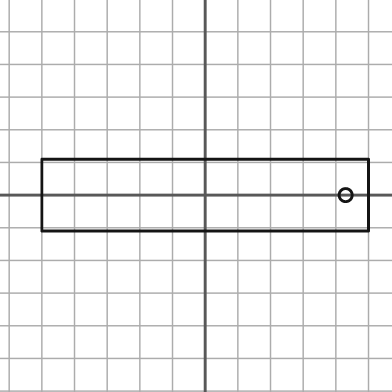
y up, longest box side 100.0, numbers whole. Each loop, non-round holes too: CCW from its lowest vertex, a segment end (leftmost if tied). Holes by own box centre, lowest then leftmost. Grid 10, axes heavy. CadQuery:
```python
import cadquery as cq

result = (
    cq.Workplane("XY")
    .moveTo(-50.0, -11.0)
    .lineTo(50.0, -11.0)
    .lineTo(50.0, 11.0)
    .lineTo(-50.0, 11.0)
    .close()
    .moveTo(43.0, 0.0)
    .circle(2.0)
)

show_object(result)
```